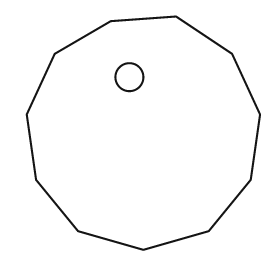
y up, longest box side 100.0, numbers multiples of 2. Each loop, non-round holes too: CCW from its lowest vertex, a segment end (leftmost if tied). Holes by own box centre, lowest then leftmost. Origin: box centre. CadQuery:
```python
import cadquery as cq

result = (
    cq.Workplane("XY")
    .moveTo(0.0, -50.0)
    .lineTo(28.0, -42.0)
    .lineTo(46.0, -20.0)
    .lineTo(50.0, 8.0)
    .lineTo(38.0, 34.0)
    .lineTo(14.0, 50.0)
    .lineTo(-14.0, 48.0)
    .lineTo(-38.0, 34.0)
    .lineTo(-50.0, 8.0)
    .lineTo(-46.0, -20.0)
    .lineTo(-28.0, -42.0)
    .close()
    .moveTo(-6.0, 24.0)
    .circle(6.0)
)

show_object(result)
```